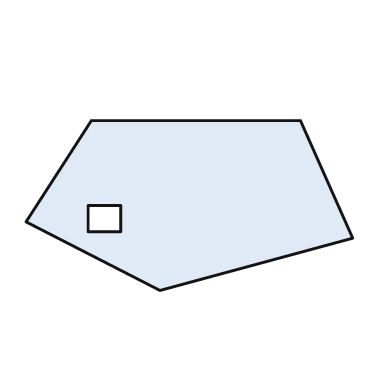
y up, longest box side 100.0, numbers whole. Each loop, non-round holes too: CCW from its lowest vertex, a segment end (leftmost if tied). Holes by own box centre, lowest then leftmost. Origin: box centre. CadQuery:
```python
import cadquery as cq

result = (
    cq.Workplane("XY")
    .moveTo(-9.0, -26.0)
    .lineTo(50.0, -10.0)
    .lineTo(34.0, 26.0)
    .lineTo(-30.0, 26.0)
    .lineTo(-50.0, -5.0)
    .close()
    .moveTo(-31.0, -8.0)
    .lineTo(-21.0, -8.0)
    .lineTo(-21.0, 0.0)
    .lineTo(-31.0, 0.0)
    .close()
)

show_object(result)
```